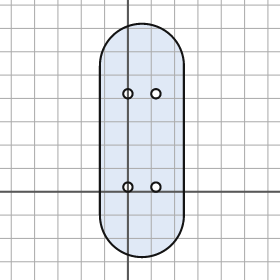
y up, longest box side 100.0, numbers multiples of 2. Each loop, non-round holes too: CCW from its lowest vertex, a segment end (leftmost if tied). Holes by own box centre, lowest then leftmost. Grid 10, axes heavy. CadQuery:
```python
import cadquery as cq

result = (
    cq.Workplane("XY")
    .moveTo(-12.0, -10.0)
    .threePointArc((6.0, -28.0), (24.0, -10.0))
    .lineTo(24.0, 54.0)
    .threePointArc((6.0, 72.0), (-12.0, 54.0))
    .close()
    .moveTo(0.0, 2.0)
    .circle(2.0)
    .moveTo(12.0, 2.0)
    .circle(2.0)
    .moveTo(0.0, 42.0)
    .circle(2.0)
    .moveTo(12.0, 42.0)
    .circle(2.0)
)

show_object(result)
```